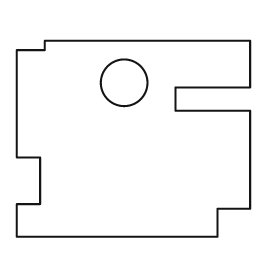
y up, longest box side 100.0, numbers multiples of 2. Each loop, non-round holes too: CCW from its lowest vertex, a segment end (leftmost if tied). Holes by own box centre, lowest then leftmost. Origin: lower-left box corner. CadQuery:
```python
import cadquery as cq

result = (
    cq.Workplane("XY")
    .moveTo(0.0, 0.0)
    .lineTo(86.0, 0.0)
    .lineTo(86.0, 12.0)
    .lineTo(100.0, 12.0)
    .lineTo(100.0, 54.0)
    .lineTo(68.0, 54.0)
    .lineTo(68.0, 64.0)
    .lineTo(100.0, 64.0)
    .lineTo(100.0, 84.0)
    .lineTo(12.0, 84.0)
    .lineTo(12.0, 80.0)
    .lineTo(0.0, 80.0)
    .lineTo(0.0, 34.0)
    .lineTo(10.0, 34.0)
    .lineTo(10.0, 14.0)
    .lineTo(0.0, 14.0)
    .close()
    .moveTo(46.0, 66.0)
    .circle(10.0)
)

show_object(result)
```